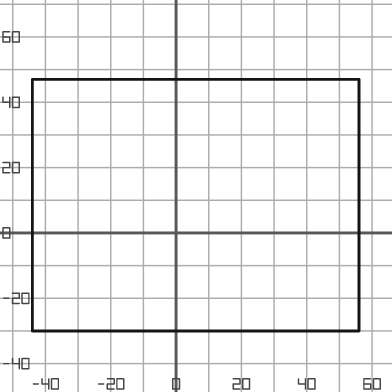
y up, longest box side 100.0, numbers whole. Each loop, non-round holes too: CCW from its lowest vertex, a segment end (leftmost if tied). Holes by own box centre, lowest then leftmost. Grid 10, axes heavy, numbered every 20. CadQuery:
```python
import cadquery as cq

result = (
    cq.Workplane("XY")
    .moveTo(-44.0, -30.0)
    .lineTo(56.0, -30.0)
    .lineTo(56.0, 47.0)
    .lineTo(-44.0, 47.0)
    .close()
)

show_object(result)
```